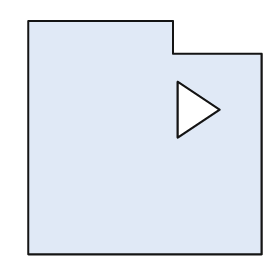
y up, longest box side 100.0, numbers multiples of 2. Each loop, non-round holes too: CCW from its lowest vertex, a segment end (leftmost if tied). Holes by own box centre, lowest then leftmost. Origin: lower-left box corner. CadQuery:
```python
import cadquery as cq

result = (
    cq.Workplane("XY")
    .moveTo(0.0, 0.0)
    .lineTo(100.0, 0.0)
    .lineTo(100.0, 86.0)
    .lineTo(62.0, 86.0)
    .lineTo(62.0, 100.0)
    .lineTo(0.0, 100.0)
    .close()
    .moveTo(64.0, 50.0)
    .lineTo(82.0, 62.0)
    .lineTo(64.0, 74.0)
    .close()
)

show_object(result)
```